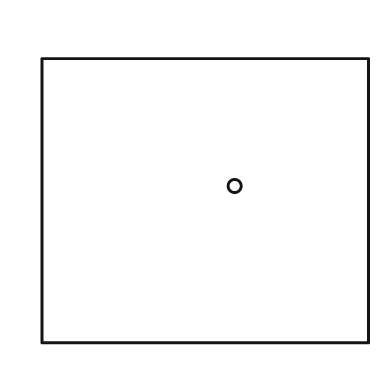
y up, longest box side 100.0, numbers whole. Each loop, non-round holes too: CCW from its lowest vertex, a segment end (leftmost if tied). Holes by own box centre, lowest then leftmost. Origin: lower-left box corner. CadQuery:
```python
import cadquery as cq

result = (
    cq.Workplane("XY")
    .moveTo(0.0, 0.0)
    .lineTo(100.0, 0.0)
    .lineTo(100.0, 87.0)
    .lineTo(0.0, 87.0)
    .close()
    .moveTo(59.0, 48.0)
    .circle(2.0)
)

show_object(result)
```